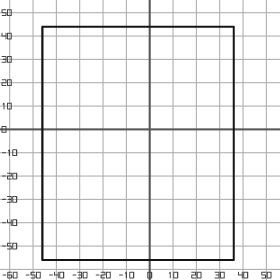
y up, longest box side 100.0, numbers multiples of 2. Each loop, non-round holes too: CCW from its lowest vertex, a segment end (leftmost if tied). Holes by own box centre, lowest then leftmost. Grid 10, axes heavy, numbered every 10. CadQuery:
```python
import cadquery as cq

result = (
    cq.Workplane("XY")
    .moveTo(-46.0, -56.0)
    .lineTo(36.0, -56.0)
    .lineTo(36.0, 44.0)
    .lineTo(-46.0, 44.0)
    .close()
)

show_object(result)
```